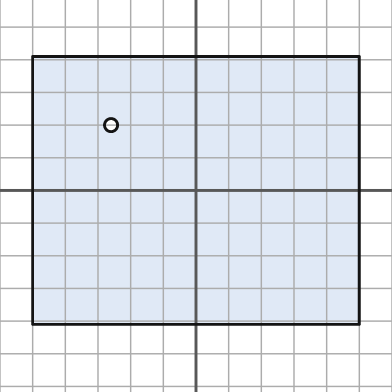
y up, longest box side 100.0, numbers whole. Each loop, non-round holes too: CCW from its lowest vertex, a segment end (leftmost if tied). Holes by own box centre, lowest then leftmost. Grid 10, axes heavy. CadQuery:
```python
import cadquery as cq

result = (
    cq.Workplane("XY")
    .moveTo(-50.0, -41.0)
    .lineTo(50.0, -41.0)
    .lineTo(50.0, 41.0)
    .lineTo(-50.0, 41.0)
    .close()
    .moveTo(-26.0, 20.0)
    .circle(2.0)
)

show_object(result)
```